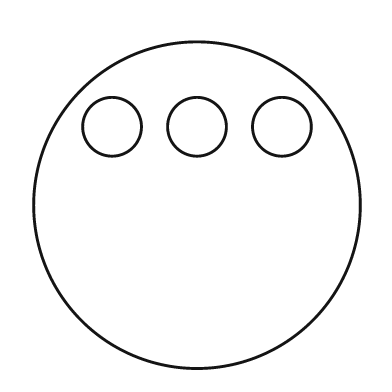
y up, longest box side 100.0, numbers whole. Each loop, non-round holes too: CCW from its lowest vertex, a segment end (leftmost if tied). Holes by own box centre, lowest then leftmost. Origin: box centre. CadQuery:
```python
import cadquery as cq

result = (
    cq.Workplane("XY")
    .moveTo(0.0, 0.0)
    .circle(50.0)
    .moveTo(-26.0, 24.0)
    .circle(9.0)
    .moveTo(0.0, 24.0)
    .circle(9.0)
    .moveTo(26.0, 24.0)
    .circle(9.0)
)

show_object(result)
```